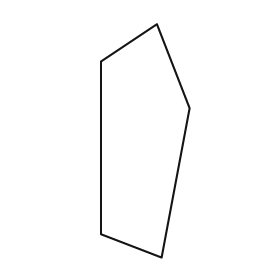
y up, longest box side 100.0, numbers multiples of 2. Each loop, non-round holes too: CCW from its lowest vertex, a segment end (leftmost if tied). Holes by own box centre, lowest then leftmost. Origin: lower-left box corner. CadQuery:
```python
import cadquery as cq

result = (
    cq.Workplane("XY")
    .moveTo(26.0, 0.0)
    .lineTo(38.0, 64.0)
    .lineTo(24.0, 100.0)
    .lineTo(0.0, 84.0)
    .lineTo(0.0, 10.0)
    .close()
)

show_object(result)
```